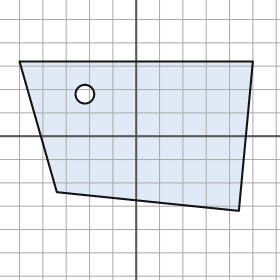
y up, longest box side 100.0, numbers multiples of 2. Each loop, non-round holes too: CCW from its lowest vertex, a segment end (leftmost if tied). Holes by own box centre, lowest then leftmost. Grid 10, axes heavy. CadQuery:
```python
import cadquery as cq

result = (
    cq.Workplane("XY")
    .moveTo(44.0, -32.0)
    .lineTo(50.0, 32.0)
    .lineTo(-50.0, 32.0)
    .lineTo(-34.0, -24.0)
    .close()
    .moveTo(-22.0, 18.0)
    .circle(4.0)
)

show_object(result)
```